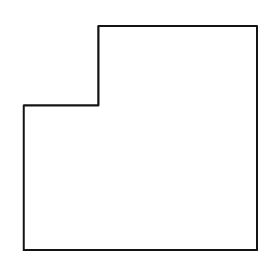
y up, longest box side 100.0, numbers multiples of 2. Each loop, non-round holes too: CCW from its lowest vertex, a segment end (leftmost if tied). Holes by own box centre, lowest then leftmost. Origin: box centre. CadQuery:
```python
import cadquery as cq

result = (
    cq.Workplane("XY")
    .moveTo(-50.0, -48.0)
    .lineTo(50.0, -48.0)
    .lineTo(50.0, 48.0)
    .lineTo(-18.0, 48.0)
    .lineTo(-18.0, 14.0)
    .lineTo(-50.0, 14.0)
    .close()
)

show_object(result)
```